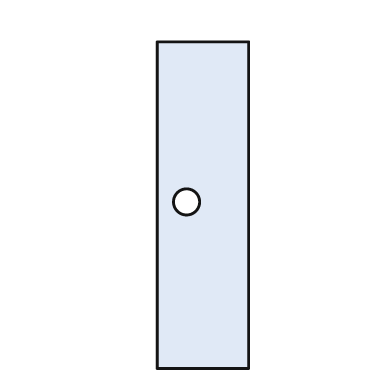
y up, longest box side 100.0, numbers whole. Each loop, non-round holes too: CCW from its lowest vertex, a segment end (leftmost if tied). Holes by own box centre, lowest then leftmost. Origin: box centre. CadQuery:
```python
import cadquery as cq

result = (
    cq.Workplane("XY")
    .moveTo(-14.0, -50.0)
    .lineTo(14.0, -50.0)
    .lineTo(14.0, 50.0)
    .lineTo(-14.0, 50.0)
    .close()
    .moveTo(-5.0, 1.0)
    .circle(4.0)
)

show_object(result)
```